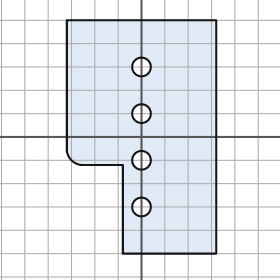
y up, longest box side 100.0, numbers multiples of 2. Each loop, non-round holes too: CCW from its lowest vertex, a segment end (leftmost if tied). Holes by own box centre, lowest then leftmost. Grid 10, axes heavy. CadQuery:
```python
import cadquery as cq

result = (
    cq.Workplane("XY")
    .moveTo(-8.0, -50.0)
    .lineTo(32.0, -50.0)
    .lineTo(32.0, 50.0)
    .lineTo(-32.0, 50.0)
    .lineTo(-32.0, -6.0)
    .threePointArc((-30.0, -10.0), (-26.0, -12.0))
    .lineTo(-8.0, -12.0)
    .close()
    .moveTo(0.0, -30.0)
    .circle(4.0)
    .moveTo(0.0, -10.0)
    .circle(4.0)
    .moveTo(0.0, 10.0)
    .circle(4.0)
    .moveTo(0.0, 30.0)
    .circle(4.0)
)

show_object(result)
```